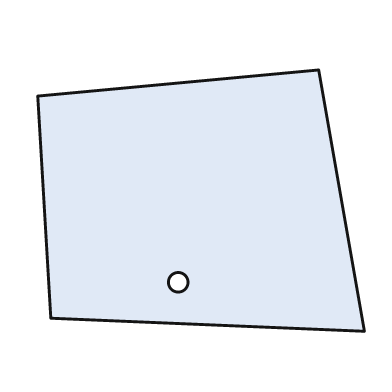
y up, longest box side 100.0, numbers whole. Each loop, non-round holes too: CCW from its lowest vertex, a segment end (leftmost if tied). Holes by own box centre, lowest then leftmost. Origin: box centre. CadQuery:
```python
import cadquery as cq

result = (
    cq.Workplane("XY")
    .moveTo(50.0, -40.0)
    .lineTo(36.0, 40.0)
    .lineTo(-50.0, 32.0)
    .lineTo(-46.0, -36.0)
    .close()
    .moveTo(-7.0, -25.0)
    .circle(3.0)
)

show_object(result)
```